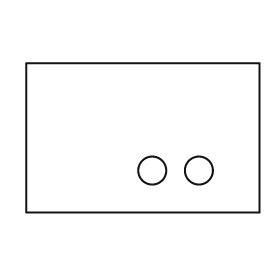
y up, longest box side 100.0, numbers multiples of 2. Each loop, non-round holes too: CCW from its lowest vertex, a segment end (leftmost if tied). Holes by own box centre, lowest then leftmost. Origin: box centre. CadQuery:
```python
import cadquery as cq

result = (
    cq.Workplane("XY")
    .moveTo(-50.0, -32.0)
    .lineTo(50.0, -32.0)
    .lineTo(50.0, 32.0)
    .lineTo(-50.0, 32.0)
    .close()
    .moveTo(4.0, -14.0)
    .circle(6.0)
    .moveTo(24.0, -14.0)
    .circle(6.0)
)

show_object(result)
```